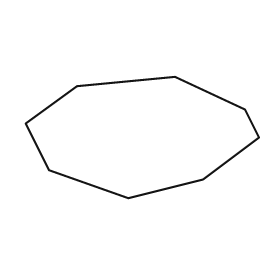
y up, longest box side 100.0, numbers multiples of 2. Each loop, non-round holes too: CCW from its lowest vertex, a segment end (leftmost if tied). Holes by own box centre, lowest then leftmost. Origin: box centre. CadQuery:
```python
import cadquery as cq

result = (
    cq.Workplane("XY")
    .moveTo(-6.0, -26.0)
    .lineTo(26.0, -18.0)
    .lineTo(50.0, 0.0)
    .lineTo(44.0, 12.0)
    .lineTo(14.0, 26.0)
    .lineTo(-28.0, 22.0)
    .lineTo(-50.0, 6.0)
    .lineTo(-40.0, -14.0)
    .close()
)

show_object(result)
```